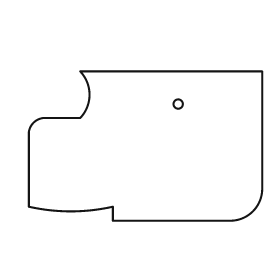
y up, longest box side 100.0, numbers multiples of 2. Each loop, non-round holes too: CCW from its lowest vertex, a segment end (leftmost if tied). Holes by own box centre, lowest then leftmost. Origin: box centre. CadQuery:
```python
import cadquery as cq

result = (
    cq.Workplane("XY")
    .moveTo(-14.0, -32.0)
    .lineTo(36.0, -32.0)
    .threePointArc((46.0, -28.0), (50.0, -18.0))
    .lineTo(50.0, 32.0)
    .lineTo(-28.0, 32.0)
    .threePointArc((-24.0, 22.0), (-28.0, 12.0))
    .lineTo(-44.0, 12.0)
    .threePointArc((-48.0, 10.0), (-50.0, 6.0))
    .lineTo(-50.0, -26.0)
    .threePointArc((-32.0, -28.0), (-14.0, -26.0))
    .close()
    .moveTo(14.0, 18.0)
    .circle(2.0)
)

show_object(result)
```